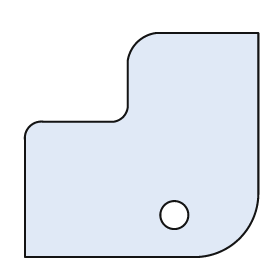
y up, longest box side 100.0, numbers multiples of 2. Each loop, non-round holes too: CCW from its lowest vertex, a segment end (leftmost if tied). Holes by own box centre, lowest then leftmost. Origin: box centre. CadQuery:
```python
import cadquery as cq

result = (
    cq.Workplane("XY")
    .moveTo(-50.0, -48.0)
    .lineTo(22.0, -48.0)
    .threePointArc((42.0, -40.0), (50.0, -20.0))
    .lineTo(50.0, 48.0)
    .lineTo(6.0, 48.0)
    .threePointArc((-2.0, 44.0), (-6.0, 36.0))
    .lineTo(-6.0, 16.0)
    .threePointArc((-8.0, 12.0), (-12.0, 10.0))
    .lineTo(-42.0, 10.0)
    .threePointArc((-48.0, 8.0), (-50.0, 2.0))
    .close()
    .moveTo(14.0, -30.0)
    .circle(6.0)
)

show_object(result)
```